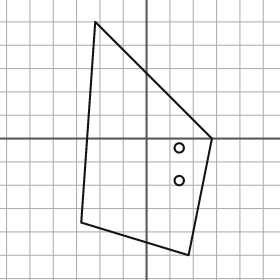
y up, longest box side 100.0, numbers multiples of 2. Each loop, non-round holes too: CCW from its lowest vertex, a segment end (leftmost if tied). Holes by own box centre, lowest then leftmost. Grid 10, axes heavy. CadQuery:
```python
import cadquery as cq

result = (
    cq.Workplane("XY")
    .moveTo(18.0, -50.0)
    .lineTo(28.0, 0.0)
    .lineTo(-22.0, 50.0)
    .lineTo(-28.0, -36.0)
    .close()
    .moveTo(14.0, -18.0)
    .circle(2.0)
    .moveTo(14.0, -4.0)
    .circle(2.0)
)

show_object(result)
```